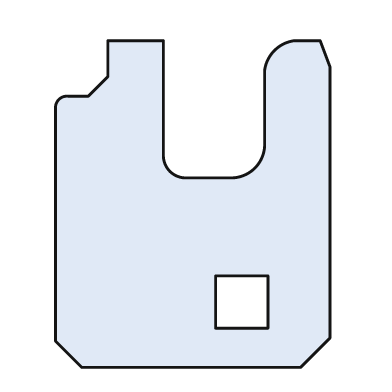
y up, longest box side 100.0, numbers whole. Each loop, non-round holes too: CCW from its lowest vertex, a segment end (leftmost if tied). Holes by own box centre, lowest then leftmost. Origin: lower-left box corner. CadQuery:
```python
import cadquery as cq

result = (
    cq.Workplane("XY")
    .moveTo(8.0, 0.0)
    .lineTo(75.0, 0.0)
    .lineTo(84.0, 9.0)
    .lineTo(84.0, 92.0)
    .lineTo(81.0, 100.0)
    .lineTo(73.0, 100.0)
    .threePointArc((67.0, 97.0), (64.0, 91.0))
    .lineTo(64.0, 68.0)
    .threePointArc((61.0, 61.0), (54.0, 58.0))
    .lineTo(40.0, 58.0)
    .threePointArc((35.0, 60.0), (33.0, 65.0))
    .lineTo(33.0, 100.0)
    .lineTo(16.0, 100.0)
    .lineTo(16.0, 89.0)
    .lineTo(10.0, 83.0)
    .lineTo(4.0, 83.0)
    .threePointArc((1.0, 82.0), (0.0, 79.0))
    .lineTo(0.0, 8.0)
    .close()
    .moveTo(49.0, 12.0)
    .lineTo(65.0, 12.0)
    .lineTo(65.0, 28.0)
    .lineTo(49.0, 28.0)
    .close()
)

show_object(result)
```